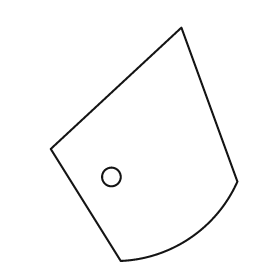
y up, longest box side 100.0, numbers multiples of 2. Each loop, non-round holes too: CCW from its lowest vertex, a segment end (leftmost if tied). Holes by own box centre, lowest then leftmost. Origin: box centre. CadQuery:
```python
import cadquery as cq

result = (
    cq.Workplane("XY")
    .moveTo(-10.0, -50.0)
    .threePointArc((20.0, -40.0), (40.0, -16.0))
    .lineTo(16.0, 50.0)
    .lineTo(-40.0, -2.0)
    .close()
    .moveTo(-14.0, -14.0)
    .circle(4.0)
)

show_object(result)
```